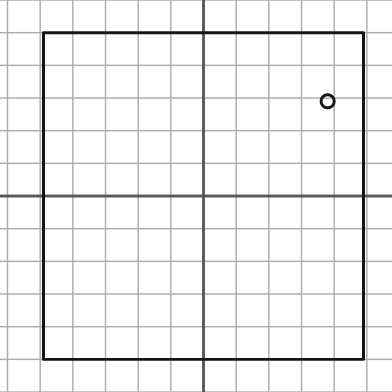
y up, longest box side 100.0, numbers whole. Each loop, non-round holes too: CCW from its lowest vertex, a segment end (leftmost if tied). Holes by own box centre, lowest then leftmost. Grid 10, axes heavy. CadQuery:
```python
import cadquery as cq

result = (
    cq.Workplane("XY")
    .moveTo(-49.0, -50.0)
    .lineTo(49.0, -50.0)
    .lineTo(49.0, 50.0)
    .lineTo(-49.0, 50.0)
    .close()
    .moveTo(38.0, 29.0)
    .circle(2.0)
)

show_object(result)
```